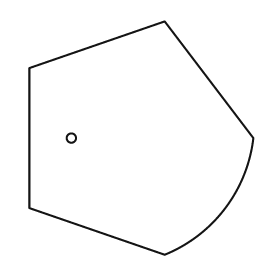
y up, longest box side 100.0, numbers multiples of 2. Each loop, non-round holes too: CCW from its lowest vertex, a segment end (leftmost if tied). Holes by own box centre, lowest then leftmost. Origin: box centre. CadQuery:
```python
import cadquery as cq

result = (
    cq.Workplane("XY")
    .moveTo(10.0, -50.0)
    .threePointArc((36.0, -30.0), (48.0, 0.0))
    .lineTo(10.0, 50.0)
    .lineTo(-48.0, 30.0)
    .lineTo(-48.0, -30.0)
    .close()
    .moveTo(-30.0, 0.0)
    .circle(2.0)
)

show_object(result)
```